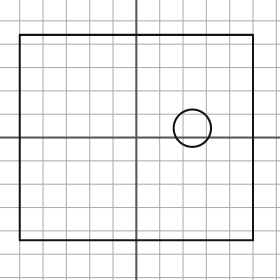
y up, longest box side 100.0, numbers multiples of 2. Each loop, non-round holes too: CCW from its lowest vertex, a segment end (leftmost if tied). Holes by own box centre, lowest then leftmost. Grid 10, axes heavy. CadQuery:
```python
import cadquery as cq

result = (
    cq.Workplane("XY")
    .moveTo(-50.0, -44.0)
    .lineTo(50.0, -44.0)
    .lineTo(50.0, 44.0)
    .lineTo(-50.0, 44.0)
    .close()
    .moveTo(24.0, 4.0)
    .circle(8.0)
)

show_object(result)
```